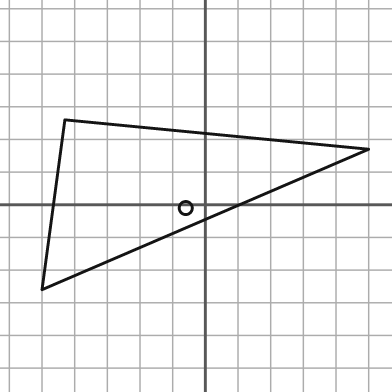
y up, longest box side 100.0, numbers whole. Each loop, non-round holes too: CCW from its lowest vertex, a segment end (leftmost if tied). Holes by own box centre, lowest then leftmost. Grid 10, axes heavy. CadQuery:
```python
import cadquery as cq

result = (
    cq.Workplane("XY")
    .moveTo(-50.0, -26.0)
    .lineTo(50.0, 17.0)
    .lineTo(-43.0, 26.0)
    .close()
    .moveTo(-6.0, -1.0)
    .circle(2.0)
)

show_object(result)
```